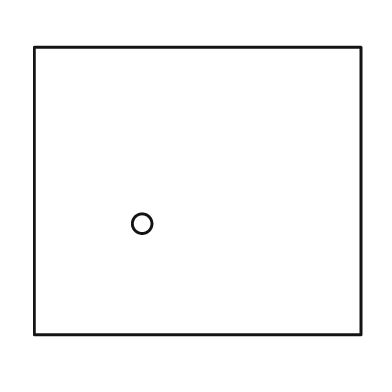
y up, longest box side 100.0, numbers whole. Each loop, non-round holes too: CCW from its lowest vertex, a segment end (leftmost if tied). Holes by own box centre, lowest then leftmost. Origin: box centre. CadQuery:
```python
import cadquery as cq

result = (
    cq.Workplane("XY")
    .moveTo(-50.0, -44.0)
    .lineTo(50.0, -44.0)
    .lineTo(50.0, 44.0)
    .lineTo(-50.0, 44.0)
    .close()
    .moveTo(-17.0, -10.0)
    .circle(3.0)
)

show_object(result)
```